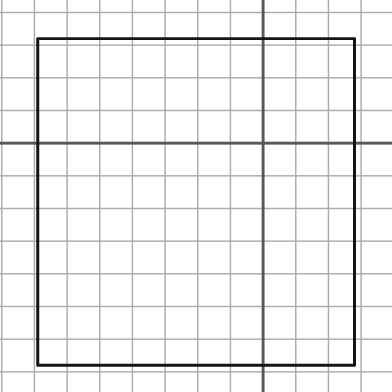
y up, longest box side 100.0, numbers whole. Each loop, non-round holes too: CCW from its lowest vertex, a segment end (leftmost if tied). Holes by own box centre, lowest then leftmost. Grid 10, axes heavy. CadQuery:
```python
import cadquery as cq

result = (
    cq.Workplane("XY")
    .moveTo(-69.0, -68.0)
    .lineTo(28.0, -68.0)
    .lineTo(28.0, 32.0)
    .lineTo(-69.0, 32.0)
    .close()
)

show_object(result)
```